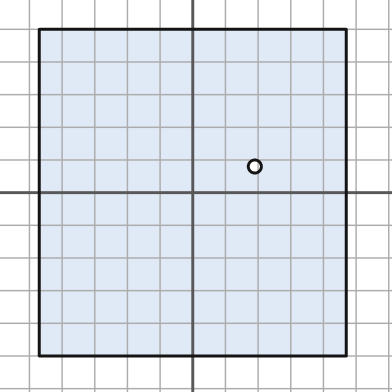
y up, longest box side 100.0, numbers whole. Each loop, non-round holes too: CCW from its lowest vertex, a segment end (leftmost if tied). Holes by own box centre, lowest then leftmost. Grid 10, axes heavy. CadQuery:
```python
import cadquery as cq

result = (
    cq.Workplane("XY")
    .moveTo(-47.0, -50.0)
    .lineTo(47.0, -50.0)
    .lineTo(47.0, 50.0)
    .lineTo(-47.0, 50.0)
    .close()
    .moveTo(19.0, 8.0)
    .circle(2.0)
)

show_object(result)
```